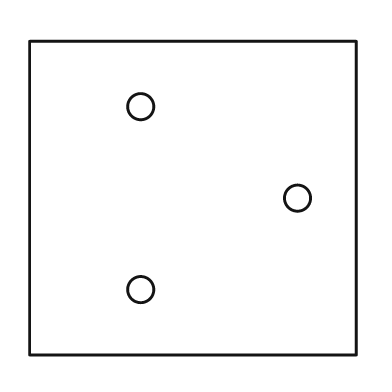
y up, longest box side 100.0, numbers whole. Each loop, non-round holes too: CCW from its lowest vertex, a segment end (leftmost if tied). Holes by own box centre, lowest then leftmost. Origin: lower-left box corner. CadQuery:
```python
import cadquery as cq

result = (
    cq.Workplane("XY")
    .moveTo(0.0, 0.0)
    .lineTo(100.0, 0.0)
    .lineTo(100.0, 96.0)
    .lineTo(0.0, 96.0)
    .close()
    .moveTo(34.0, 20.0)
    .circle(4.0)
    .moveTo(82.0, 48.0)
    .circle(4.0)
    .moveTo(34.0, 76.0)
    .circle(4.0)
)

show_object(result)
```